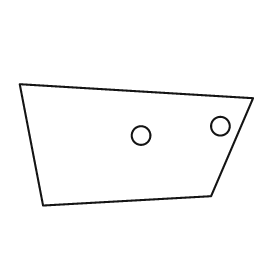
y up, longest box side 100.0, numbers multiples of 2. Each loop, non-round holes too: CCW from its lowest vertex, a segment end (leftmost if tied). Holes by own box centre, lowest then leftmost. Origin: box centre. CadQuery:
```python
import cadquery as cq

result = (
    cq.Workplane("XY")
    .moveTo(-40.0, -26.0)
    .lineTo(32.0, -22.0)
    .lineTo(50.0, 20.0)
    .lineTo(-50.0, 26.0)
    .close()
    .moveTo(2.0, 4.0)
    .circle(4.0)
    .moveTo(36.0, 8.0)
    .circle(4.0)
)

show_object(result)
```